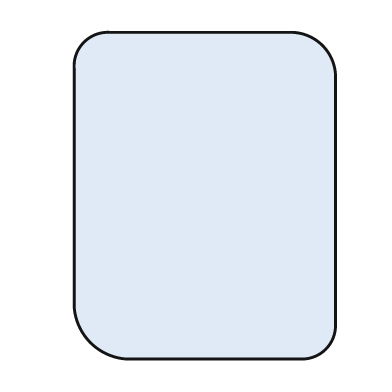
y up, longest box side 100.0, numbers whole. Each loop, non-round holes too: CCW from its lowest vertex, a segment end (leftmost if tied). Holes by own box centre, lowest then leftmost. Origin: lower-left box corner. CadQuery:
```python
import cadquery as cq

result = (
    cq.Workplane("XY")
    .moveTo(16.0, 0.0)
    .lineTo(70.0, 0.0)
    .threePointArc((77.0, 3.0), (80.0, 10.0))
    .lineTo(80.0, 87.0)
    .threePointArc((76.0, 96.0), (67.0, 100.0))
    .lineTo(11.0, 100.0)
    .threePointArc((3.0, 97.0), (0.0, 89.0))
    .lineTo(0.0, 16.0)
    .threePointArc((5.0, 5.0), (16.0, 0.0))
    .close()
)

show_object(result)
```